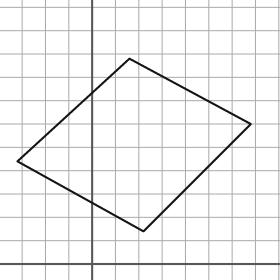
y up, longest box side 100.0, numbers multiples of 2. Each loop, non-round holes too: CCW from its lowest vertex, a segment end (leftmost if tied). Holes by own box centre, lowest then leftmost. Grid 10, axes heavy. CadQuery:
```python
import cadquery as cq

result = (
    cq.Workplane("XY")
    .moveTo(22.0, 14.0)
    .lineTo(68.0, 60.0)
    .lineTo(16.0, 88.0)
    .lineTo(-32.0, 44.0)
    .close()
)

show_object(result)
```